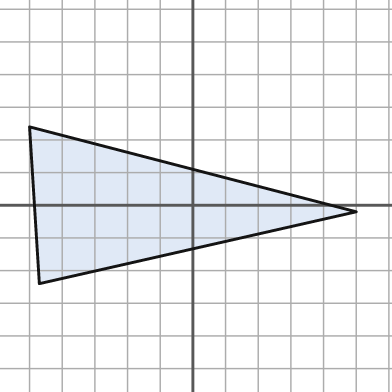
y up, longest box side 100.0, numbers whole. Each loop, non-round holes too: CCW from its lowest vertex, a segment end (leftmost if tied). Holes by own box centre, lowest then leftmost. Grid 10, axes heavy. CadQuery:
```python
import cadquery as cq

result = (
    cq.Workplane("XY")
    .moveTo(-47.0, -24.0)
    .lineTo(50.0, -2.0)
    .lineTo(-50.0, 24.0)
    .close()
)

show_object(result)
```